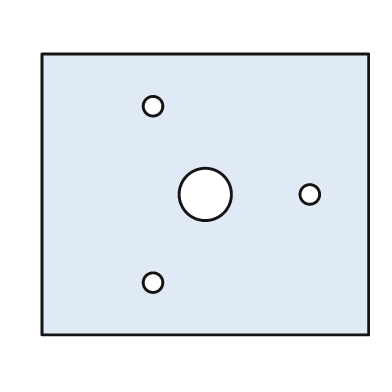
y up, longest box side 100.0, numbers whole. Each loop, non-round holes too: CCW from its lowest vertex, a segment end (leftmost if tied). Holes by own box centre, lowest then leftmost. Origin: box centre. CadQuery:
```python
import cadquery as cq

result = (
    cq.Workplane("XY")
    .moveTo(-50.0, -43.0)
    .lineTo(50.0, -43.0)
    .lineTo(50.0, 43.0)
    .lineTo(-50.0, 43.0)
    .close()
    .moveTo(-16.0, -27.0)
    .circle(3.0)
    .moveTo(0.0, 0.0)
    .circle(8.0)
    .moveTo(32.0, 0.0)
    .circle(3.0)
    .moveTo(-16.0, 27.0)
    .circle(3.0)
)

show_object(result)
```